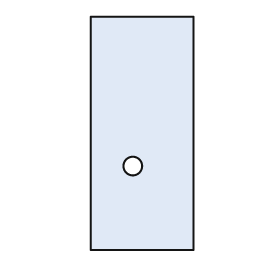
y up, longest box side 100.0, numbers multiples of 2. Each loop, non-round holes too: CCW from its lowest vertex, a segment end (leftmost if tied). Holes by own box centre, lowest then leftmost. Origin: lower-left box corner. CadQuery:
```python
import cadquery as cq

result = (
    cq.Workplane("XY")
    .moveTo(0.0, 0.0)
    .lineTo(44.0, 0.0)
    .lineTo(44.0, 100.0)
    .lineTo(0.0, 100.0)
    .close()
    .moveTo(18.0, 36.0)
    .circle(4.0)
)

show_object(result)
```